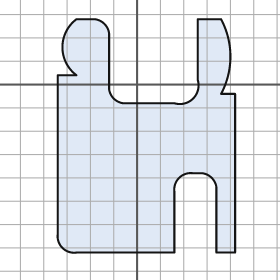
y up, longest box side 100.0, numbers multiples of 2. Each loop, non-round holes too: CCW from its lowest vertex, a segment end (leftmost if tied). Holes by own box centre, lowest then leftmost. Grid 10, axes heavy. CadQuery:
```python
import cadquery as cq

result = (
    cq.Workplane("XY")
    .moveTo(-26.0, -72.0)
    .lineTo(16.0, -72.0)
    .lineTo(16.0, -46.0)
    .threePointArc((18.0, -40.0), (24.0, -38.0))
    .lineTo(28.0, -38.0)
    .threePointArc((32.0, -40.0), (34.0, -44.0))
    .lineTo(34.0, -72.0)
    .lineTo(42.0, -72.0)
    .lineTo(42.0, -4.0)
    .lineTo(36.0, -4.0)
    .threePointArc((40.0, 12.0), (36.0, 28.0))
    .lineTo(26.0, 28.0)
    .lineTo(26.0, 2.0)
    .threePointArc((24.0, -6.0), (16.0, -8.0))
    .lineTo(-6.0, -8.0)
    .threePointArc((-10.0, -6.0), (-12.0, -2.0))
    .lineTo(-12.0, 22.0)
    .threePointArc((-14.0, 26.0), (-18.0, 28.0))
    .lineTo(-26.0, 28.0)
    .threePointArc((-32.0, 16.0), (-26.0, 4.0))
    .lineTo(-34.0, 4.0)
    .lineTo(-34.0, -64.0)
    .threePointArc((-32.0, -70.0), (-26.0, -72.0))
    .close()
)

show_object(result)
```